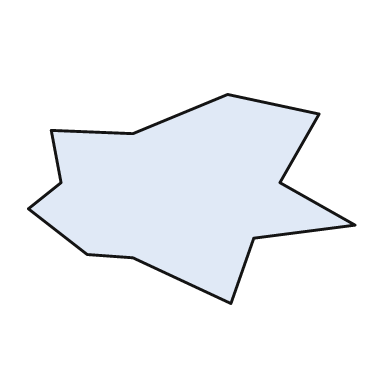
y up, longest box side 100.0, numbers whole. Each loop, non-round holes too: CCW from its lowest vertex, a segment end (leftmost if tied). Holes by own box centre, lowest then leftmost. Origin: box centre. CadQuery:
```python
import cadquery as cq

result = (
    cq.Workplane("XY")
    .moveTo(12.0, -32.0)
    .lineTo(19.0, -12.0)
    .lineTo(50.0, -8.0)
    .lineTo(27.0, 5.0)
    .lineTo(39.0, 26.0)
    .lineTo(11.0, 32.0)
    .lineTo(-18.0, 20.0)
    .lineTo(-43.0, 21.0)
    .lineTo(-40.0, 5.0)
    .lineTo(-50.0, -3.0)
    .lineTo(-32.0, -17.0)
    .lineTo(-18.0, -18.0)
    .close()
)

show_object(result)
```